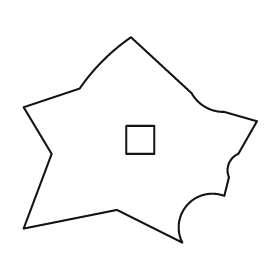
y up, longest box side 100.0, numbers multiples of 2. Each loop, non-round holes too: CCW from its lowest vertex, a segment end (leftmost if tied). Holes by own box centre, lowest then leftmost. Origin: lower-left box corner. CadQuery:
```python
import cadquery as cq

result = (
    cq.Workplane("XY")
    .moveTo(68.0, 0.0)
    .threePointArc((70.0, 16.0), (86.0, 20.0))
    .lineTo(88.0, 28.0)
    .threePointArc((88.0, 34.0), (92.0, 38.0))
    .lineTo(100.0, 52.0)
    .lineTo(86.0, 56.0)
    .threePointArc((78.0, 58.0), (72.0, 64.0))
    .lineTo(46.0, 88.0)
    .threePointArc((34.0, 78.0), (24.0, 66.0))
    .lineTo(0.0, 58.0)
    .lineTo(12.0, 38.0)
    .lineTo(0.0, 6.0)
    .lineTo(40.0, 14.0)
    .close()
    .moveTo(44.0, 38.0)
    .lineTo(56.0, 38.0)
    .lineTo(56.0, 50.0)
    .lineTo(44.0, 50.0)
    .close()
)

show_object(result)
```